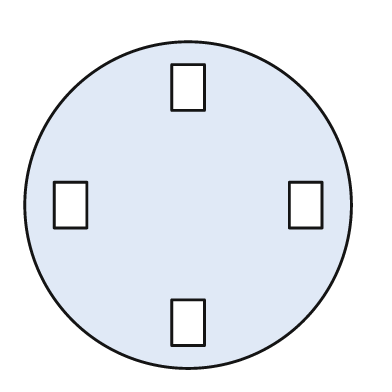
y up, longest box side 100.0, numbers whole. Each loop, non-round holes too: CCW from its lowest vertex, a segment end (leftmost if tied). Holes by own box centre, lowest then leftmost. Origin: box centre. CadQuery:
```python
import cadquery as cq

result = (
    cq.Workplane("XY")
    .moveTo(0.0, 0.0)
    .circle(50.0)
    .moveTo(-5.0, -43.0)
    .lineTo(5.0, -43.0)
    .lineTo(5.0, -29.0)
    .lineTo(-5.0, -29.0)
    .close()
    .moveTo(-41.0, -7.0)
    .lineTo(-31.0, -7.0)
    .lineTo(-31.0, 7.0)
    .lineTo(-41.0, 7.0)
    .close()
    .moveTo(31.0, -7.0)
    .lineTo(41.0, -7.0)
    .lineTo(41.0, 7.0)
    .lineTo(31.0, 7.0)
    .close()
    .moveTo(-5.0, 29.0)
    .lineTo(5.0, 29.0)
    .lineTo(5.0, 43.0)
    .lineTo(-5.0, 43.0)
    .close()
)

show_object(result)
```